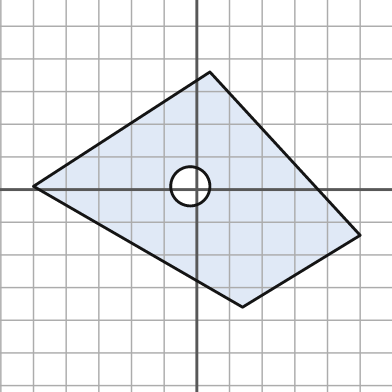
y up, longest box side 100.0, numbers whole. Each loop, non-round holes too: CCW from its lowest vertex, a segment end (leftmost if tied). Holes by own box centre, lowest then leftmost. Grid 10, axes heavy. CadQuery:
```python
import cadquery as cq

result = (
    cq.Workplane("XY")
    .moveTo(14.0, -36.0)
    .lineTo(50.0, -14.0)
    .lineTo(4.0, 36.0)
    .lineTo(-50.0, 1.0)
    .close()
    .moveTo(-2.0, 1.0)
    .circle(6.0)
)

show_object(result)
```